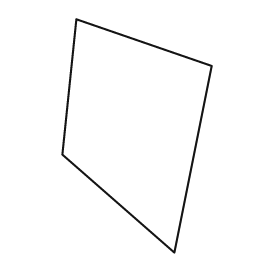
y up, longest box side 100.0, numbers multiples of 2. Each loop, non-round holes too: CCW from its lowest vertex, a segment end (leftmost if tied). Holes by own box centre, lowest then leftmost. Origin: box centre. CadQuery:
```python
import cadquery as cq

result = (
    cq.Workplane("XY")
    .moveTo(16.0, -50.0)
    .lineTo(32.0, 30.0)
    .lineTo(-26.0, 50.0)
    .lineTo(-32.0, -8.0)
    .close()
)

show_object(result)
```